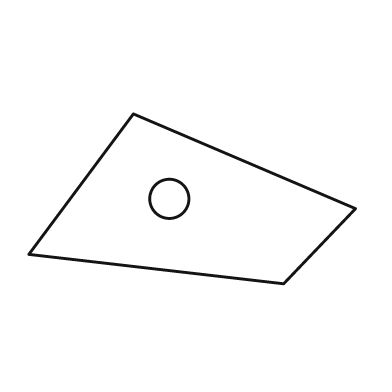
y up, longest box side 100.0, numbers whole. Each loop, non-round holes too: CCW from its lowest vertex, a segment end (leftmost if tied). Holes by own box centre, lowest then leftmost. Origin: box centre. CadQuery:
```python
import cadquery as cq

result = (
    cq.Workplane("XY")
    .moveTo(28.0, -26.0)
    .lineTo(50.0, -3.0)
    .lineTo(-18.0, 26.0)
    .lineTo(-50.0, -17.0)
    .close()
    .moveTo(-7.0, 0.0)
    .circle(6.0)
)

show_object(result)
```